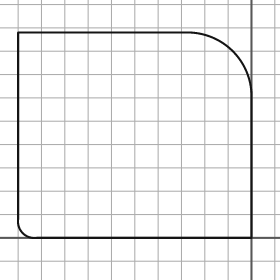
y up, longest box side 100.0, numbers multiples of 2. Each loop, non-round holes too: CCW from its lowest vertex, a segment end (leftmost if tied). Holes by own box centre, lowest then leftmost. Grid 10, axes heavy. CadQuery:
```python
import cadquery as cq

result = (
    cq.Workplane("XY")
    .moveTo(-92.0, 0.0)
    .lineTo(0.0, 0.0)
    .lineTo(0.0, 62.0)
    .threePointArc((-8.0, 80.0), (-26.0, 88.0))
    .lineTo(-100.0, 88.0)
    .lineTo(-100.0, 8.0)
    .threePointArc((-98.0, 2.0), (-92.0, 0.0))
    .close()
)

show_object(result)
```